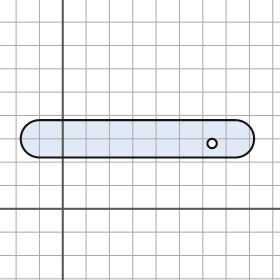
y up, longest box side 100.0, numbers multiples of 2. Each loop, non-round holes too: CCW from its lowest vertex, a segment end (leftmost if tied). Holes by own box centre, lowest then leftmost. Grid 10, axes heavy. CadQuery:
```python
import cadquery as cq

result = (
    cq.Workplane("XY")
    .moveTo(-10.0, 22.0)
    .lineTo(74.0, 22.0)
    .threePointArc((82.0, 30.0), (74.0, 38.0))
    .lineTo(-10.0, 38.0)
    .threePointArc((-18.0, 30.0), (-10.0, 22.0))
    .close()
    .moveTo(64.0, 28.0)
    .circle(2.0)
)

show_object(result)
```